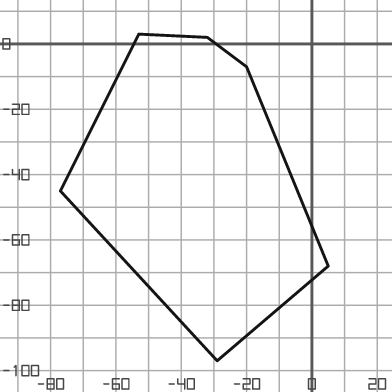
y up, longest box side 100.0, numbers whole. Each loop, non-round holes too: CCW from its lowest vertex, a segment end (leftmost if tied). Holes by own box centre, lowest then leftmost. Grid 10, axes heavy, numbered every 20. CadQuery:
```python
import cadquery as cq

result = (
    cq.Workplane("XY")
    .moveTo(-29.0, -97.0)
    .lineTo(5.0, -68.0)
    .lineTo(-20.0, -7.0)
    .lineTo(-32.0, 2.0)
    .lineTo(-53.0, 3.0)
    .lineTo(-77.0, -45.0)
    .close()
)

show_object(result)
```